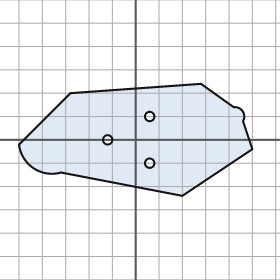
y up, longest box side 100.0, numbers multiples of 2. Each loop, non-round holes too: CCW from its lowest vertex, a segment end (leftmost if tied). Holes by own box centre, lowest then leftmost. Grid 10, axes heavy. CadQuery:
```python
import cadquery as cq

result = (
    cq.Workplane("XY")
    .moveTo(20.0, -24.0)
    .lineTo(50.0, -4.0)
    .lineTo(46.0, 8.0)
    .threePointArc((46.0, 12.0), (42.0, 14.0))
    .lineTo(28.0, 24.0)
    .lineTo(-28.0, 20.0)
    .lineTo(-50.0, -2.0)
    .threePointArc((-44.0, -12.0), (-32.0, -14.0))
    .close()
    .moveTo(6.0, -10.0)
    .circle(2.0)
    .moveTo(-12.0, 0.0)
    .circle(2.0)
    .moveTo(6.0, 10.0)
    .circle(2.0)
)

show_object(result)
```